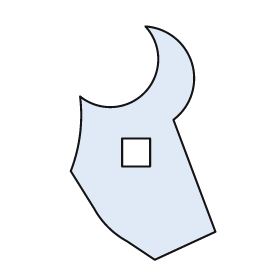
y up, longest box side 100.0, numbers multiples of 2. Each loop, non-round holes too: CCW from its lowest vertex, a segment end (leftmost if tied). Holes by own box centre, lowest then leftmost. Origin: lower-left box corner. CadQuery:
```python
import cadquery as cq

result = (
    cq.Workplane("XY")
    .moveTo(36.0, 0.0)
    .lineTo(62.0, 12.0)
    .lineTo(44.0, 60.0)
    .threePointArc((52.0, 84.0), (32.0, 100.0))
    .threePointArc((32.0, 72.0), (4.0, 70.0))
    .threePointArc((4.0, 54.0), (0.0, 38.0))
    .lineTo(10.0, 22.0)
    .threePointArc((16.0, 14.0), (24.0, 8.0))
    .close()
    .moveTo(22.0, 40.0)
    .lineTo(34.0, 40.0)
    .lineTo(34.0, 52.0)
    .lineTo(22.0, 52.0)
    .close()
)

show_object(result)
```